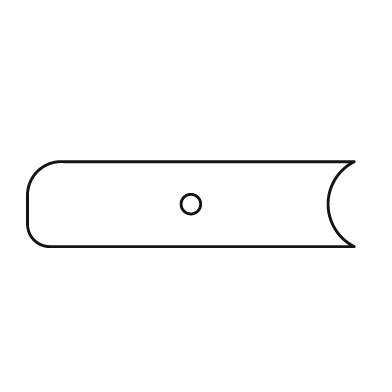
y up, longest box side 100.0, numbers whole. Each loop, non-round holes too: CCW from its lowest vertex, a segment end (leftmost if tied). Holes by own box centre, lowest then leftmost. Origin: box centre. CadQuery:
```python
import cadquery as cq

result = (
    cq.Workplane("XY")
    .moveTo(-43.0, -13.0)
    .lineTo(50.0, -13.0)
    .threePointArc((42.0, 0.0), (50.0, 13.0))
    .lineTo(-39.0, 13.0)
    .threePointArc((-47.0, 10.0), (-50.0, 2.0))
    .lineTo(-50.0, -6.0)
    .threePointArc((-48.0, -11.0), (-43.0, -13.0))
    .close()
    .moveTo(0.0, 0.0)
    .circle(3.0)
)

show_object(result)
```